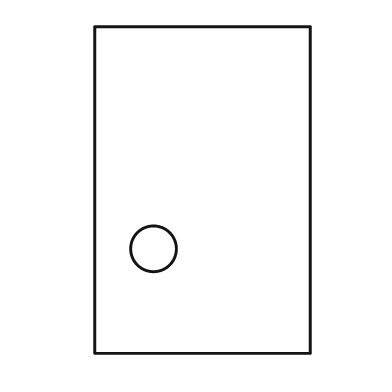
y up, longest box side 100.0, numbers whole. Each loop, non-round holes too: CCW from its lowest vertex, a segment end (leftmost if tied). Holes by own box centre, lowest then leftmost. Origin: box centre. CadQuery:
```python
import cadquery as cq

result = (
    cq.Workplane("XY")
    .moveTo(-33.0, -50.0)
    .lineTo(33.0, -50.0)
    .lineTo(33.0, 50.0)
    .lineTo(-33.0, 50.0)
    .close()
    .moveTo(-15.0, -18.0)
    .circle(7.0)
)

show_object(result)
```